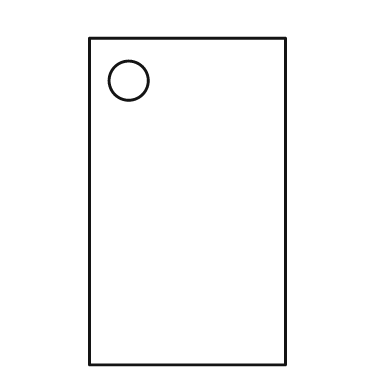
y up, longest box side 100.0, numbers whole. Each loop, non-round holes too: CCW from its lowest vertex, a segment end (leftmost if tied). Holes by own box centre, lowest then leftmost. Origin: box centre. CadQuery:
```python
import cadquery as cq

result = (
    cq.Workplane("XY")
    .moveTo(-30.0, -50.0)
    .lineTo(30.0, -50.0)
    .lineTo(30.0, 50.0)
    .lineTo(-30.0, 50.0)
    .close()
    .moveTo(-18.0, 37.0)
    .circle(6.0)
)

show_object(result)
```